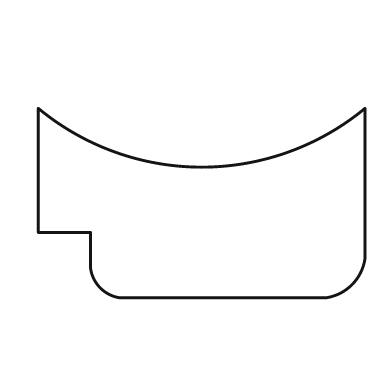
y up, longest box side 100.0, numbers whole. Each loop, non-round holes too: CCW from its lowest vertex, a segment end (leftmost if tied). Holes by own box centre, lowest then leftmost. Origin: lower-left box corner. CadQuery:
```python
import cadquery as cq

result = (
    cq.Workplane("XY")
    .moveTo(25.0, 0.0)
    .lineTo(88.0, 0.0)
    .threePointArc((96.0, 4.0), (100.0, 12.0))
    .lineTo(100.0, 58.0)
    .threePointArc((50.0, 40.0), (0.0, 58.0))
    .lineTo(0.0, 20.0)
    .lineTo(16.0, 20.0)
    .lineTo(16.0, 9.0)
    .threePointArc((19.0, 3.0), (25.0, 0.0))
    .close()
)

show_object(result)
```